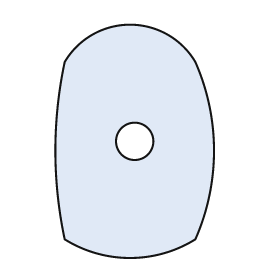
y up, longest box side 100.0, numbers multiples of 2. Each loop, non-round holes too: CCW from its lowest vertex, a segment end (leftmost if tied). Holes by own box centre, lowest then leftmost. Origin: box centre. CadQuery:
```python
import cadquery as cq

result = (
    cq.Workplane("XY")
    .moveTo(-30.0, -42.0)
    .threePointArc((-2.0, -50.0), (26.0, -42.0))
    .threePointArc((34.0, -4.0), (26.0, 34.0))
    .threePointArc((-2.0, 50.0), (-30.0, 34.0))
    .threePointArc((-34.0, -4.0), (-30.0, -42.0))
    .close()
    .moveTo(0.0, 0.0)
    .circle(8.0)
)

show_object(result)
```